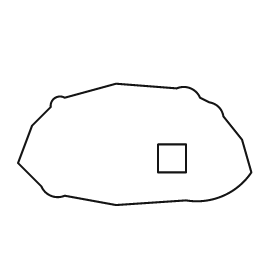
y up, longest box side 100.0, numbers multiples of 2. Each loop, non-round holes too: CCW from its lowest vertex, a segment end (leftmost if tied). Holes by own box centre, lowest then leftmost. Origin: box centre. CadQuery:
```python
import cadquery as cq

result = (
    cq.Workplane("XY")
    .moveTo(-8.0, -26.0)
    .lineTo(22.0, -24.0)
    .threePointArc((38.0, -22.0), (50.0, -12.0))
    .lineTo(46.0, 2.0)
    .lineTo(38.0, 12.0)
    .threePointArc((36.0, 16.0), (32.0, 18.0))
    .lineTo(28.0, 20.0)
    .threePointArc((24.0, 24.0), (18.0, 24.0))
    .lineTo(-8.0, 26.0)
    .lineTo(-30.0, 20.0)
    .threePointArc((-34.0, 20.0), (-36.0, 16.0))
    .lineTo(-44.0, 8.0)
    .lineTo(-50.0, -8.0)
    .lineTo(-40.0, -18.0)
    .threePointArc((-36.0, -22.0), (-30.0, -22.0))
    .close()
    .moveTo(10.0, -12.0)
    .lineTo(22.0, -12.0)
    .lineTo(22.0, 0.0)
    .lineTo(10.0, 0.0)
    .close()
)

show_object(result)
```